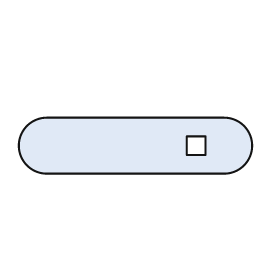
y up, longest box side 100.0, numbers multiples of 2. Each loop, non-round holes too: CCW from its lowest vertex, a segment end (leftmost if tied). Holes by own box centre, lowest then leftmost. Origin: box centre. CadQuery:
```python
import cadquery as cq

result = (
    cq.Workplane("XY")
    .moveTo(-38.0, -12.0)
    .lineTo(38.0, -12.0)
    .threePointArc((50.0, 0.0), (38.0, 12.0))
    .lineTo(-38.0, 12.0)
    .threePointArc((-50.0, 0.0), (-38.0, -12.0))
    .close()
    .moveTo(22.0, -4.0)
    .lineTo(30.0, -4.0)
    .lineTo(30.0, 4.0)
    .lineTo(22.0, 4.0)
    .close()
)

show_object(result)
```